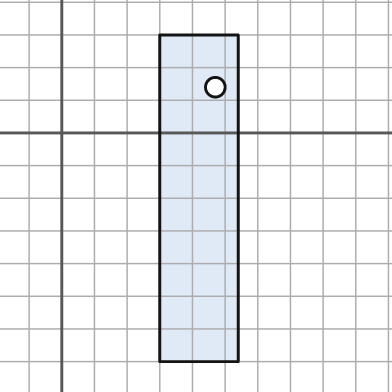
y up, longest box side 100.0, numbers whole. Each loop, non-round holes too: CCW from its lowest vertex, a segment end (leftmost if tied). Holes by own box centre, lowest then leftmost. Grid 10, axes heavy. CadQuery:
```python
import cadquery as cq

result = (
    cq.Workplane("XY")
    .moveTo(30.0, -70.0)
    .lineTo(54.0, -70.0)
    .lineTo(54.0, 30.0)
    .lineTo(30.0, 30.0)
    .close()
    .moveTo(47.0, 14.0)
    .circle(3.0)
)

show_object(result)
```